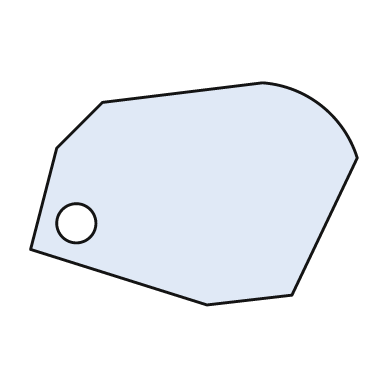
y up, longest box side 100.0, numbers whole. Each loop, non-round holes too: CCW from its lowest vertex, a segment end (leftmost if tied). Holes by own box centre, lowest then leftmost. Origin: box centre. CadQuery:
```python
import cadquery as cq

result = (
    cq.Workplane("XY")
    .moveTo(4.0, -34.0)
    .lineTo(30.0, -31.0)
    .lineTo(50.0, 11.0)
    .threePointArc((39.0, 27.0), (21.0, 34.0))
    .lineTo(-28.0, 28.0)
    .lineTo(-42.0, 14.0)
    .lineTo(-50.0, -17.0)
    .close()
    .moveTo(-36.0, -9.0)
    .circle(6.0)
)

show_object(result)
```